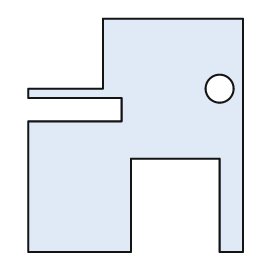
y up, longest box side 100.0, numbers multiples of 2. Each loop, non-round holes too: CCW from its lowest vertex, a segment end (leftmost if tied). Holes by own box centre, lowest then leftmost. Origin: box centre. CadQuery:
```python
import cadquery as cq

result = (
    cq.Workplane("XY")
    .moveTo(-46.0, -50.0)
    .lineTo(-2.0, -50.0)
    .lineTo(-2.0, -10.0)
    .lineTo(36.0, -10.0)
    .lineTo(36.0, -50.0)
    .lineTo(46.0, -50.0)
    .lineTo(46.0, 50.0)
    .lineTo(-14.0, 50.0)
    .lineTo(-14.0, 20.0)
    .lineTo(-46.0, 20.0)
    .lineTo(-46.0, 16.0)
    .lineTo(-6.0, 16.0)
    .lineTo(-6.0, 6.0)
    .lineTo(-46.0, 6.0)
    .close()
    .moveTo(36.0, 20.0)
    .circle(6.0)
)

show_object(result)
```